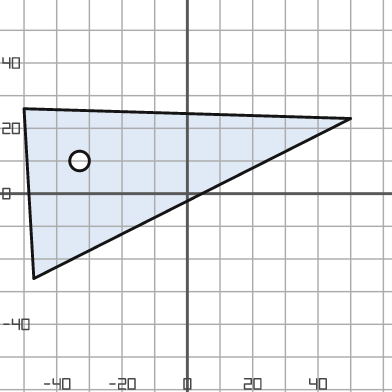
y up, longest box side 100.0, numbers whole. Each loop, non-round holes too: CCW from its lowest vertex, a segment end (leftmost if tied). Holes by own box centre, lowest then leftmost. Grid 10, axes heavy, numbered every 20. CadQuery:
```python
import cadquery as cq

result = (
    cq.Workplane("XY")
    .moveTo(-47.0, -26.0)
    .lineTo(50.0, 23.0)
    .lineTo(-50.0, 26.0)
    .close()
    .moveTo(-33.0, 10.0)
    .circle(3.0)
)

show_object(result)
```